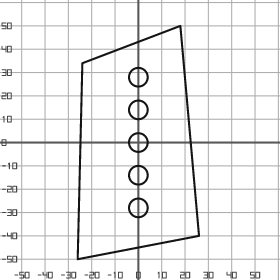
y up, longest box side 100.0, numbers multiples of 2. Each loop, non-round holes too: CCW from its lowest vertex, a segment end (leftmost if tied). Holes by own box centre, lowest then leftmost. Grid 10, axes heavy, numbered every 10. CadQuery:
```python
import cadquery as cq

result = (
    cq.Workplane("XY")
    .moveTo(-26.0, -50.0)
    .lineTo(26.0, -40.0)
    .lineTo(18.0, 50.0)
    .lineTo(-24.0, 34.0)
    .close()
    .moveTo(0.0, -28.0)
    .circle(4.0)
    .moveTo(0.0, -14.0)
    .circle(4.0)
    .moveTo(0.0, 0.0)
    .circle(4.0)
    .moveTo(0.0, 14.0)
    .circle(4.0)
    .moveTo(0.0, 28.0)
    .circle(4.0)
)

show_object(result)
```